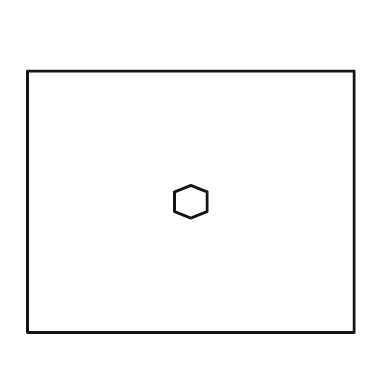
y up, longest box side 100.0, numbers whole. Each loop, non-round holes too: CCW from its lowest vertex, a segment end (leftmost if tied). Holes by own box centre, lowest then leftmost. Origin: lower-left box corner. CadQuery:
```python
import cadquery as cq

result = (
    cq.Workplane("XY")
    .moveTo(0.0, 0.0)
    .lineTo(100.0, 0.0)
    .lineTo(100.0, 80.0)
    .lineTo(0.0, 80.0)
    .close()
    .moveTo(50.0, 35.0)
    .lineTo(55.0, 37.0)
    .lineTo(55.0, 43.0)
    .lineTo(50.0, 45.0)
    .lineTo(45.0, 43.0)
    .lineTo(45.0, 37.0)
    .close()
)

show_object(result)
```